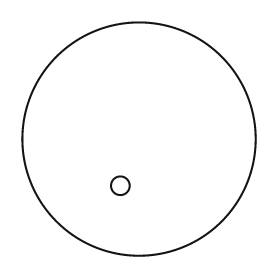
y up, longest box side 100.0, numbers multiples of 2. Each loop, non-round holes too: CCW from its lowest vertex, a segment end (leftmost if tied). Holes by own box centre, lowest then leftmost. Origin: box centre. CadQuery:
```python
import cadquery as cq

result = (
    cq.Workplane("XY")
    .moveTo(0.0, 0.0)
    .circle(50.0)
    .moveTo(-8.0, -20.0)
    .circle(4.0)
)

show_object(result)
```